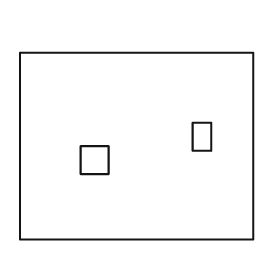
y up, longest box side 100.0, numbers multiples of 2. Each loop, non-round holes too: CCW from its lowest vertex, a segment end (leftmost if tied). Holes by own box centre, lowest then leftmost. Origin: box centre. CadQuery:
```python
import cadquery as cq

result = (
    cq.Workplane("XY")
    .moveTo(-50.0, -40.0)
    .lineTo(50.0, -40.0)
    .lineTo(50.0, 40.0)
    .lineTo(-50.0, 40.0)
    .close()
    .moveTo(-24.0, -12.0)
    .lineTo(-12.0, -12.0)
    .lineTo(-12.0, 0.0)
    .lineTo(-24.0, 0.0)
    .close()
    .moveTo(24.0, -2.0)
    .lineTo(32.0, -2.0)
    .lineTo(32.0, 10.0)
    .lineTo(24.0, 10.0)
    .close()
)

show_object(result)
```